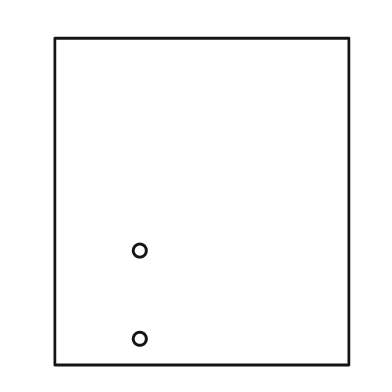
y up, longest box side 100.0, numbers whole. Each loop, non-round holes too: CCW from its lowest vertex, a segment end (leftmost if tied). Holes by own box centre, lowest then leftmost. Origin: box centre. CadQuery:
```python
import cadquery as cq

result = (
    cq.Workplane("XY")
    .moveTo(-45.0, -50.0)
    .lineTo(45.0, -50.0)
    .lineTo(45.0, 50.0)
    .lineTo(-45.0, 50.0)
    .close()
    .moveTo(-19.0, -42.0)
    .circle(2.0)
    .moveTo(-19.0, -15.0)
    .circle(2.0)
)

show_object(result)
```